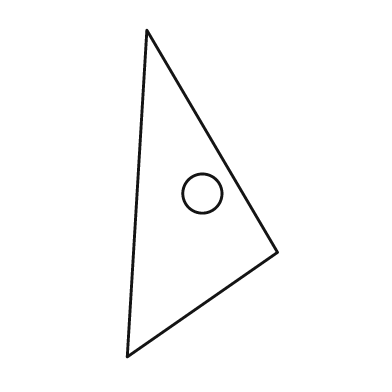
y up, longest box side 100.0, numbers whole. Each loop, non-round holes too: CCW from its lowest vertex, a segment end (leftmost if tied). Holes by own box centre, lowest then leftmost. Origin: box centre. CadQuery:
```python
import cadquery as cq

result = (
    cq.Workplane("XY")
    .moveTo(-23.0, -50.0)
    .lineTo(23.0, -18.0)
    .lineTo(-17.0, 50.0)
    .close()
    .moveTo(0.0, 0.0)
    .circle(6.0)
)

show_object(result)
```